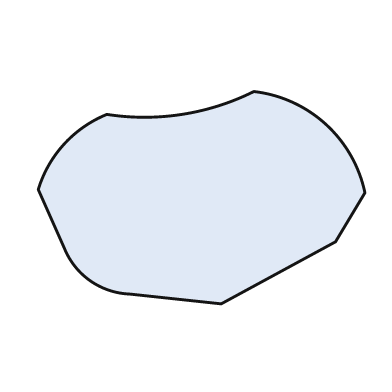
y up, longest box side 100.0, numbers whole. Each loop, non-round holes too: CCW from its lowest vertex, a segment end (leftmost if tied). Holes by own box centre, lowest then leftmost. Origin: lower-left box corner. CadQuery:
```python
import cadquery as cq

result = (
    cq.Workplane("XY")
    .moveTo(56.0, 0.0)
    .lineTo(91.0, 19.0)
    .lineTo(100.0, 34.0)
    .threePointArc((88.0, 55.0), (66.0, 65.0))
    .threePointArc((44.0, 58.0), (21.0, 58.0))
    .threePointArc((8.0, 49.0), (0.0, 35.0))
    .lineTo(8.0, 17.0)
    .threePointArc((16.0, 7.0), (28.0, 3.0))
    .close()
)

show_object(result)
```